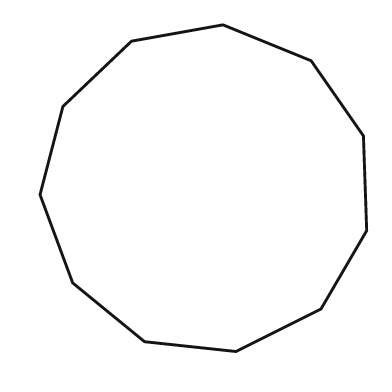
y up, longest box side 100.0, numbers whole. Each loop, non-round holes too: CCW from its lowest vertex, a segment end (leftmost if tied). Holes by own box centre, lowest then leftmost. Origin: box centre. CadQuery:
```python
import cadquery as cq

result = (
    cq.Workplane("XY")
    .moveTo(10.0, -50.0)
    .lineTo(36.0, -37.0)
    .lineTo(50.0, -13.0)
    .lineTo(49.0, 16.0)
    .lineTo(33.0, 39.0)
    .lineTo(6.0, 50.0)
    .lineTo(-22.0, 45.0)
    .lineTo(-43.0, 25.0)
    .lineTo(-50.0, -2.0)
    .lineTo(-40.0, -29.0)
    .lineTo(-18.0, -47.0)
    .close()
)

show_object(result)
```